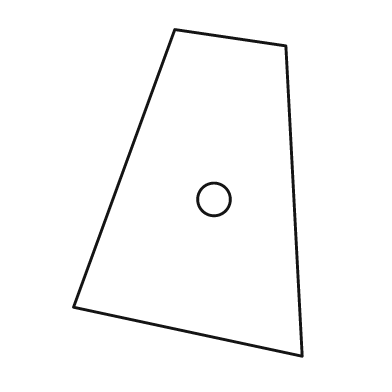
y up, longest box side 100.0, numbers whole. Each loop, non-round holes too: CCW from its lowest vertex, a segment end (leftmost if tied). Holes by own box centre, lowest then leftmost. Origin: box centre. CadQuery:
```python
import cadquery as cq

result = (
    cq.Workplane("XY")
    .moveTo(35.0, -50.0)
    .lineTo(30.0, 45.0)
    .lineTo(-4.0, 50.0)
    .lineTo(-35.0, -35.0)
    .close()
    .moveTo(8.0, -2.0)
    .circle(5.0)
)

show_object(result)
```